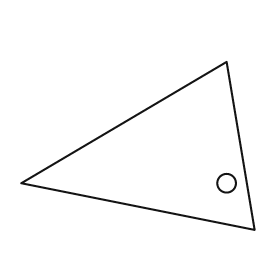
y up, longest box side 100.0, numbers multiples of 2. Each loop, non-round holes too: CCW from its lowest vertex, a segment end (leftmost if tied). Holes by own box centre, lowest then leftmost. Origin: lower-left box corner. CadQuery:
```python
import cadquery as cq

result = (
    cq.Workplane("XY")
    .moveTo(100.0, 0.0)
    .lineTo(88.0, 72.0)
    .lineTo(0.0, 20.0)
    .close()
    .moveTo(88.0, 20.0)
    .circle(4.0)
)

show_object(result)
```